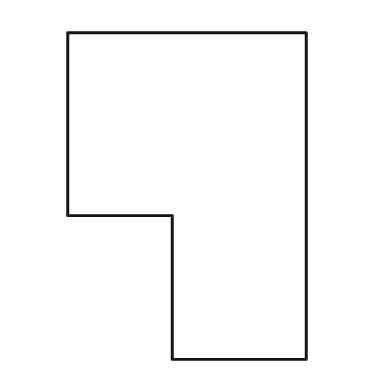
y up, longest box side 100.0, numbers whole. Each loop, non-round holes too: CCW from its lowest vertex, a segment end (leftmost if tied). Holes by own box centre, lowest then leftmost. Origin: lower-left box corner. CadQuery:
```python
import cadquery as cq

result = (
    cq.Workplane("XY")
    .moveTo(32.0, 0.0)
    .lineTo(73.0, 0.0)
    .lineTo(73.0, 100.0)
    .lineTo(0.0, 100.0)
    .lineTo(0.0, 44.0)
    .lineTo(32.0, 44.0)
    .close()
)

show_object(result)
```